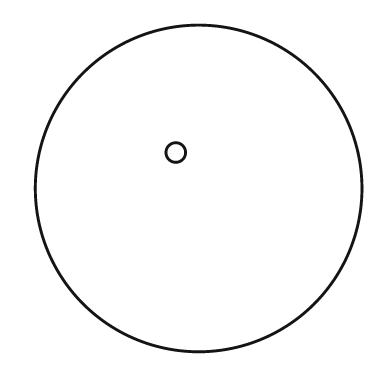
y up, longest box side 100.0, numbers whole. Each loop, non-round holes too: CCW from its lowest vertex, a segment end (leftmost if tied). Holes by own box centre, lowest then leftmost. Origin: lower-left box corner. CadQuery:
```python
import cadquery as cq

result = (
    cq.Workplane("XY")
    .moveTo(50.0, 50.0)
    .circle(50.0)
    .moveTo(43.0, 61.0)
    .circle(3.0)
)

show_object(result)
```